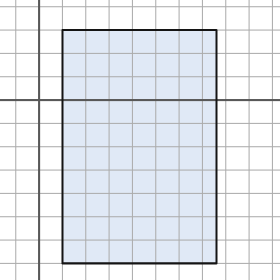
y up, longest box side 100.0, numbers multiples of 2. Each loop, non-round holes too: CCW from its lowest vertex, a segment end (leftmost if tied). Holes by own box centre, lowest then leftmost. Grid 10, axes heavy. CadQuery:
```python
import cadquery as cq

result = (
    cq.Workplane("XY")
    .moveTo(10.0, -70.0)
    .lineTo(76.0, -70.0)
    .lineTo(76.0, 30.0)
    .lineTo(10.0, 30.0)
    .close()
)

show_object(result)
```